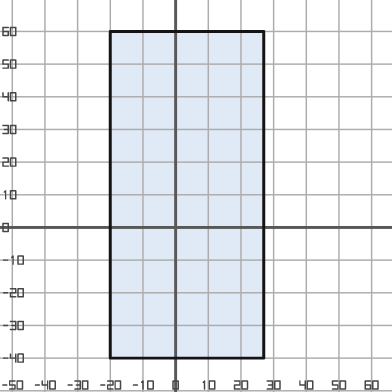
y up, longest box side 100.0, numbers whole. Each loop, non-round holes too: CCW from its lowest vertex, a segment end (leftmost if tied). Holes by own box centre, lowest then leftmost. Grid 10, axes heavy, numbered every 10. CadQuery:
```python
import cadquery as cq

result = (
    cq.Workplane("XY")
    .moveTo(-20.0, -40.0)
    .lineTo(27.0, -40.0)
    .lineTo(27.0, 60.0)
    .lineTo(-20.0, 60.0)
    .close()
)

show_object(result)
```